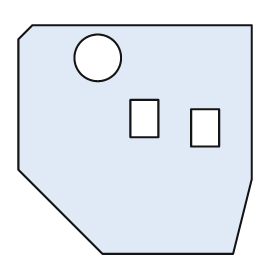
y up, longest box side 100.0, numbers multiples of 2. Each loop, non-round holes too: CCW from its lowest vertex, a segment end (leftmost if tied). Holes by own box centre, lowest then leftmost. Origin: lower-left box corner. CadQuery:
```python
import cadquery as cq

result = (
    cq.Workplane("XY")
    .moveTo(36.0, 0.0)
    .lineTo(92.0, 0.0)
    .lineTo(100.0, 32.0)
    .lineTo(100.0, 98.0)
    .lineTo(6.0, 98.0)
    .lineTo(0.0, 92.0)
    .lineTo(0.0, 36.0)
    .close()
    .moveTo(74.0, 46.0)
    .lineTo(86.0, 46.0)
    .lineTo(86.0, 62.0)
    .lineTo(74.0, 62.0)
    .close()
    .moveTo(48.0, 50.0)
    .lineTo(60.0, 50.0)
    .lineTo(60.0, 66.0)
    .lineTo(48.0, 66.0)
    .close()
    .moveTo(34.0, 84.0)
    .circle(10.0)
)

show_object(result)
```